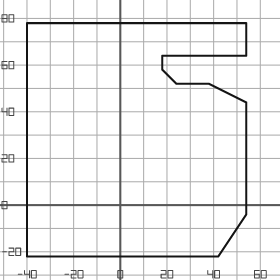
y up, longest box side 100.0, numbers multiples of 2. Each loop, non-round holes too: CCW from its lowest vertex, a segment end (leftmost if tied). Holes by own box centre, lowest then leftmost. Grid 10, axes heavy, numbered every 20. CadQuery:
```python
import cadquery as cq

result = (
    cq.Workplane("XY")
    .moveTo(-40.0, -22.0)
    .lineTo(42.0, -22.0)
    .lineTo(54.0, -4.0)
    .lineTo(54.0, 44.0)
    .lineTo(38.0, 52.0)
    .lineTo(24.0, 52.0)
    .lineTo(18.0, 58.0)
    .lineTo(18.0, 64.0)
    .lineTo(54.0, 64.0)
    .lineTo(54.0, 78.0)
    .lineTo(-40.0, 78.0)
    .close()
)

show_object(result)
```